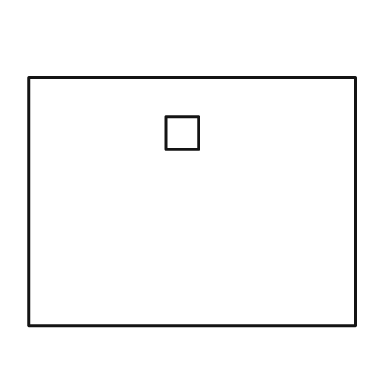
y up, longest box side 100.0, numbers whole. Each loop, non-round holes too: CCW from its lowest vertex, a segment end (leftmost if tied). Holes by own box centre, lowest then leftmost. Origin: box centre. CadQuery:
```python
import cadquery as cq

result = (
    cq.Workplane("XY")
    .moveTo(-50.0, -38.0)
    .lineTo(50.0, -38.0)
    .lineTo(50.0, 38.0)
    .lineTo(-50.0, 38.0)
    .close()
    .moveTo(-8.0, 16.0)
    .lineTo(2.0, 16.0)
    .lineTo(2.0, 26.0)
    .lineTo(-8.0, 26.0)
    .close()
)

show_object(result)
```